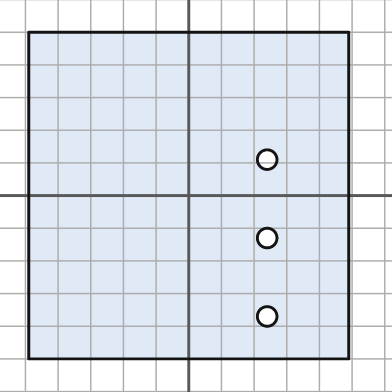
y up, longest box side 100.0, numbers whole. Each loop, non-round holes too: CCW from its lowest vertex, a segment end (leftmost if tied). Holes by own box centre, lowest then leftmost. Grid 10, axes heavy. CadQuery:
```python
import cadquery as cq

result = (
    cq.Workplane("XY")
    .moveTo(-49.0, -50.0)
    .lineTo(49.0, -50.0)
    .lineTo(49.0, 50.0)
    .lineTo(-49.0, 50.0)
    .close()
    .moveTo(24.0, -37.0)
    .circle(3.0)
    .moveTo(24.0, -13.0)
    .circle(3.0)
    .moveTo(24.0, 11.0)
    .circle(3.0)
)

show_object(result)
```